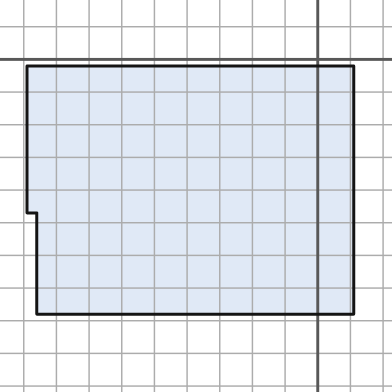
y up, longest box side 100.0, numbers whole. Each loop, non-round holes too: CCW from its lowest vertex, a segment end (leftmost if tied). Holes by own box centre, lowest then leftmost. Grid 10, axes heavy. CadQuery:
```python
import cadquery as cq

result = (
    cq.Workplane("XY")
    .moveTo(-86.0, -78.0)
    .lineTo(11.0, -78.0)
    .lineTo(11.0, -2.0)
    .lineTo(-89.0, -2.0)
    .lineTo(-89.0, -47.0)
    .lineTo(-86.0, -47.0)
    .close()
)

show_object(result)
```